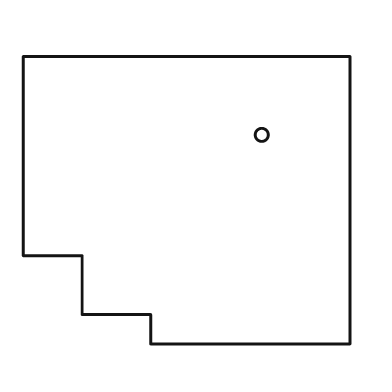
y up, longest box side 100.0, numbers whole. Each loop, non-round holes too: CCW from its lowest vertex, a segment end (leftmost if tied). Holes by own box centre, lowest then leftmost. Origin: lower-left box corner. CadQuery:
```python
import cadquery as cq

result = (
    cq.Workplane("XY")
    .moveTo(39.0, 0.0)
    .lineTo(100.0, 0.0)
    .lineTo(100.0, 88.0)
    .lineTo(0.0, 88.0)
    .lineTo(0.0, 27.0)
    .lineTo(18.0, 27.0)
    .lineTo(18.0, 9.0)
    .lineTo(39.0, 9.0)
    .close()
    .moveTo(73.0, 64.0)
    .circle(2.0)
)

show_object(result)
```